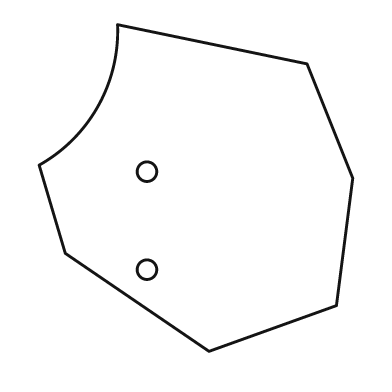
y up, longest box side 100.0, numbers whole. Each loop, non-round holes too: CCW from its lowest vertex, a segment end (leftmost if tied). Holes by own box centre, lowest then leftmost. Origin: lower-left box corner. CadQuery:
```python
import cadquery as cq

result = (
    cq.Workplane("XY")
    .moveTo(52.0, 0.0)
    .lineTo(91.0, 14.0)
    .lineTo(96.0, 53.0)
    .lineTo(82.0, 88.0)
    .lineTo(24.0, 100.0)
    .threePointArc((18.0, 75.0), (0.0, 57.0))
    .lineTo(8.0, 30.0)
    .close()
    .moveTo(33.0, 25.0)
    .circle(3.0)
    .moveTo(33.0, 55.0)
    .circle(3.0)
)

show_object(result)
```